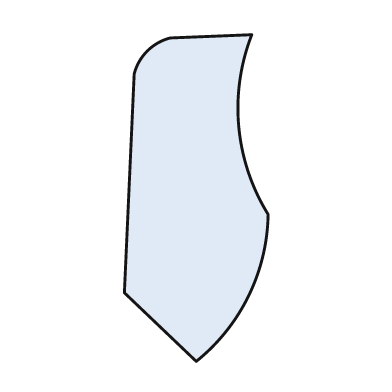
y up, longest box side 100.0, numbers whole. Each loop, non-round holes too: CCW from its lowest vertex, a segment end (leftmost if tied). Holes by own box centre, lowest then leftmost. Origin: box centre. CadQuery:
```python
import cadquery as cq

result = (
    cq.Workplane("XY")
    .moveTo(0.0, -50.0)
    .threePointArc((16.0, -30.0), (22.0, -5.0))
    .threePointArc((13.0, 22.0), (17.0, 50.0))
    .lineTo(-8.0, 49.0)
    .threePointArc((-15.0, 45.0), (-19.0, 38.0))
    .lineTo(-22.0, -29.0)
    .close()
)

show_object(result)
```